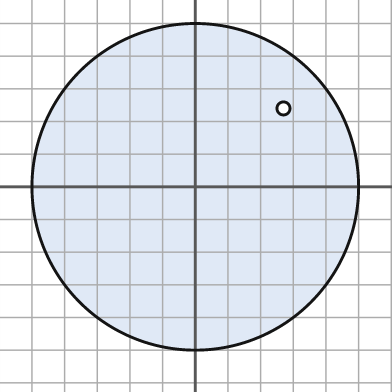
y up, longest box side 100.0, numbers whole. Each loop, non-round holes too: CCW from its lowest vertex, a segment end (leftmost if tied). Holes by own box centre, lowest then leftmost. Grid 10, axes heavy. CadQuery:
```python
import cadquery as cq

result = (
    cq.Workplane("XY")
    .moveTo(0.0, 0.0)
    .circle(50.0)
    .moveTo(27.0, 24.0)
    .circle(2.0)
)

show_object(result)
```